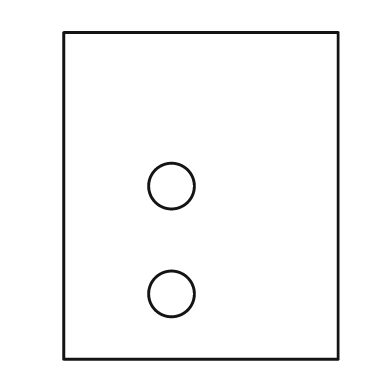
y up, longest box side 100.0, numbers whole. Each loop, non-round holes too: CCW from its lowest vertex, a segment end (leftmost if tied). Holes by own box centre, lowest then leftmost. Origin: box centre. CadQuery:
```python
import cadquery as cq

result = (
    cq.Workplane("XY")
    .moveTo(-42.0, -50.0)
    .lineTo(42.0, -50.0)
    .lineTo(42.0, 50.0)
    .lineTo(-42.0, 50.0)
    .close()
    .moveTo(-9.0, -30.0)
    .circle(7.0)
    .moveTo(-9.0, 3.0)
    .circle(7.0)
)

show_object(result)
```